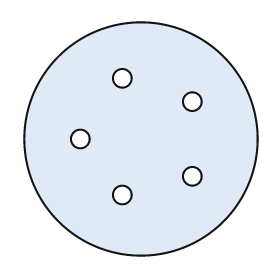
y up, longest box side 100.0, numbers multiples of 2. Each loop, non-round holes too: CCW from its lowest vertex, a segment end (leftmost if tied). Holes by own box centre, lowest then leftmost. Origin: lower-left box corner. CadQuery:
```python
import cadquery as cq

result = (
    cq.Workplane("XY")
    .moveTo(50.0, 50.0)
    .circle(50.0)
    .moveTo(42.0, 26.0)
    .circle(4.0)
    .moveTo(72.0, 34.0)
    .circle(4.0)
    .moveTo(24.0, 50.0)
    .circle(4.0)
    .moveTo(72.0, 66.0)
    .circle(4.0)
    .moveTo(42.0, 76.0)
    .circle(4.0)
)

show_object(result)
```